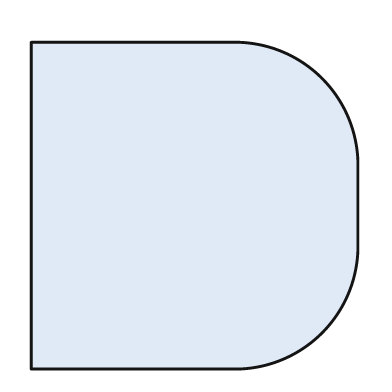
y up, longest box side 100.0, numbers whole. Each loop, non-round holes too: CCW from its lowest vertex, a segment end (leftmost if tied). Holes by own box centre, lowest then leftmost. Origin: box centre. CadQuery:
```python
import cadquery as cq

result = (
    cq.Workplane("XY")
    .moveTo(-50.0, -50.0)
    .lineTo(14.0, -50.0)
    .threePointArc((39.0, -39.0), (50.0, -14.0))
    .lineTo(50.0, 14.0)
    .threePointArc((39.0, 39.0), (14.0, 50.0))
    .lineTo(-50.0, 50.0)
    .close()
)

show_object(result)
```